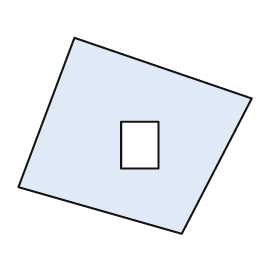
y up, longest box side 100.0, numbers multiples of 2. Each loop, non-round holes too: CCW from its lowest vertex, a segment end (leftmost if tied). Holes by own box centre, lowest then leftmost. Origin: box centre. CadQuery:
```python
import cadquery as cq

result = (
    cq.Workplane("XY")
    .moveTo(20.0, -42.0)
    .lineTo(50.0, 16.0)
    .lineTo(-26.0, 42.0)
    .lineTo(-50.0, -22.0)
    .close()
    .moveTo(-6.0, -14.0)
    .lineTo(10.0, -14.0)
    .lineTo(10.0, 6.0)
    .lineTo(-6.0, 6.0)
    .close()
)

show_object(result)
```